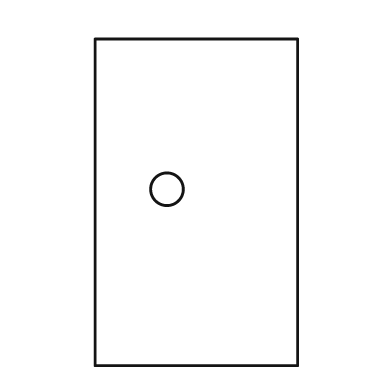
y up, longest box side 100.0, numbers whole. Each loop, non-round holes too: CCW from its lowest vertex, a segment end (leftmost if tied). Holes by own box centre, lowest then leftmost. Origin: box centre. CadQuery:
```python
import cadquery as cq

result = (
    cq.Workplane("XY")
    .moveTo(-31.0, -50.0)
    .lineTo(31.0, -50.0)
    .lineTo(31.0, 50.0)
    .lineTo(-31.0, 50.0)
    .close()
    .moveTo(-9.0, 4.0)
    .circle(5.0)
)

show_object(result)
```